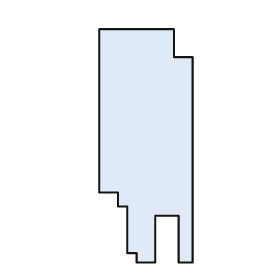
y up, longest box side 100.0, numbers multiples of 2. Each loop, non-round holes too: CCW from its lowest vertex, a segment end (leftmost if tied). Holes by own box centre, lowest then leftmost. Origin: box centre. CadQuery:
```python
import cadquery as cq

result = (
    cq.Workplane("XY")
    .moveTo(-4.0, -50.0)
    .lineTo(4.0, -50.0)
    .lineTo(4.0, -30.0)
    .lineTo(14.0, -30.0)
    .lineTo(14.0, -50.0)
    .lineTo(20.0, -50.0)
    .lineTo(20.0, 38.0)
    .lineTo(12.0, 38.0)
    .lineTo(12.0, 50.0)
    .lineTo(-20.0, 50.0)
    .lineTo(-20.0, -20.0)
    .lineTo(-12.0, -20.0)
    .lineTo(-12.0, -26.0)
    .lineTo(-8.0, -26.0)
    .lineTo(-8.0, -46.0)
    .lineTo(-4.0, -46.0)
    .close()
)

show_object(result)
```